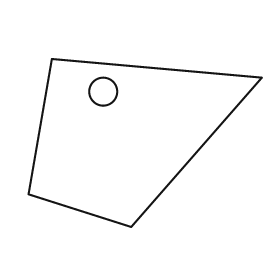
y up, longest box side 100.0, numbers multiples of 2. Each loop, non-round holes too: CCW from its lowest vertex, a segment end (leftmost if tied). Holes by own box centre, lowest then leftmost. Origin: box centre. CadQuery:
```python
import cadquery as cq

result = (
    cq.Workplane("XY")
    .moveTo(-6.0, -36.0)
    .lineTo(50.0, 28.0)
    .lineTo(-40.0, 36.0)
    .lineTo(-50.0, -22.0)
    .close()
    .moveTo(-18.0, 22.0)
    .circle(6.0)
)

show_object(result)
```